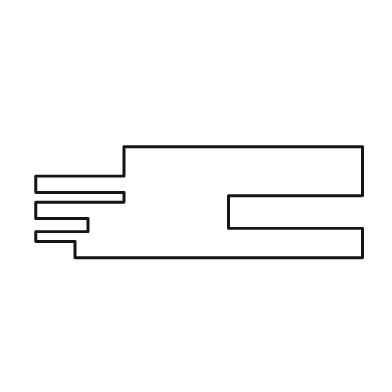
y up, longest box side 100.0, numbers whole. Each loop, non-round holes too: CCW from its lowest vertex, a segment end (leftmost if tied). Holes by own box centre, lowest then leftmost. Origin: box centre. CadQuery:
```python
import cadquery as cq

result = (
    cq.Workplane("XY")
    .moveTo(-38.0, -17.0)
    .lineTo(50.0, -17.0)
    .lineTo(50.0, -8.0)
    .lineTo(9.0, -8.0)
    .lineTo(9.0, 2.0)
    .lineTo(50.0, 2.0)
    .lineTo(50.0, 17.0)
    .lineTo(-23.0, 17.0)
    .lineTo(-23.0, 8.0)
    .lineTo(-50.0, 8.0)
    .lineTo(-50.0, 3.0)
    .lineTo(-23.0, 3.0)
    .lineTo(-23.0, 0.0)
    .lineTo(-50.0, 0.0)
    .lineTo(-50.0, -5.0)
    .lineTo(-34.0, -5.0)
    .lineTo(-34.0, -9.0)
    .lineTo(-50.0, -9.0)
    .lineTo(-50.0, -12.0)
    .lineTo(-38.0, -12.0)
    .close()
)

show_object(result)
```